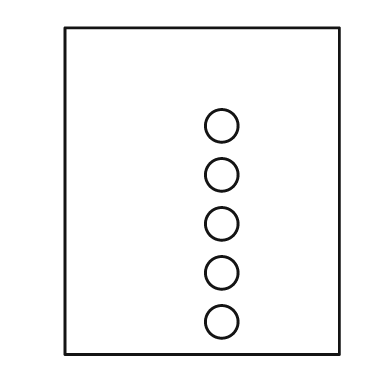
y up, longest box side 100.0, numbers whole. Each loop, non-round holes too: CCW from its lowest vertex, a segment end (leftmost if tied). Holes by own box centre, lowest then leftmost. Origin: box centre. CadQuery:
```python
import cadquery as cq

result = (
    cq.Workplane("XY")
    .moveTo(-42.0, -50.0)
    .lineTo(42.0, -50.0)
    .lineTo(42.0, 50.0)
    .lineTo(-42.0, 50.0)
    .close()
    .moveTo(6.0, -40.0)
    .circle(5.0)
    .moveTo(6.0, -25.0)
    .circle(5.0)
    .moveTo(6.0, -10.0)
    .circle(5.0)
    .moveTo(6.0, 5.0)
    .circle(5.0)
    .moveTo(6.0, 20.0)
    .circle(5.0)
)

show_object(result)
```